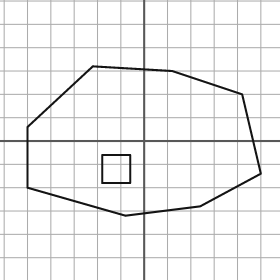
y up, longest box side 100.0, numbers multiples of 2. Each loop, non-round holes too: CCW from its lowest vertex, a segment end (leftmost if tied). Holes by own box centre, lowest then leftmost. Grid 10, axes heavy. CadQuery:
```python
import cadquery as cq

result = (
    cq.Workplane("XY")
    .moveTo(-8.0, -32.0)
    .lineTo(24.0, -28.0)
    .lineTo(50.0, -14.0)
    .lineTo(42.0, 20.0)
    .lineTo(12.0, 30.0)
    .lineTo(-22.0, 32.0)
    .lineTo(-50.0, 6.0)
    .lineTo(-50.0, -20.0)
    .close()
    .moveTo(-18.0, -18.0)
    .lineTo(-6.0, -18.0)
    .lineTo(-6.0, -6.0)
    .lineTo(-18.0, -6.0)
    .close()
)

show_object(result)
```